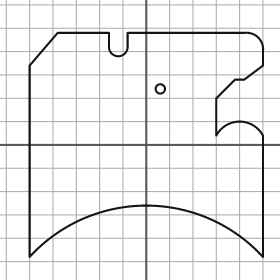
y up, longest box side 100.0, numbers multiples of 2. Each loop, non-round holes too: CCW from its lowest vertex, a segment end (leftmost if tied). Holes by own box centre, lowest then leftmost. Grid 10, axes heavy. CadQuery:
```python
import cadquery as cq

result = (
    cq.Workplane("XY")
    .moveTo(-50.0, -48.0)
    .threePointArc((0.0, -26.0), (50.0, -48.0))
    .lineTo(50.0, 4.0)
    .threePointArc((40.0, 10.0), (30.0, 4.0))
    .lineTo(30.0, 20.0)
    .lineTo(38.0, 28.0)
    .lineTo(42.0, 28.0)
    .lineTo(50.0, 34.0)
    .lineTo(50.0, 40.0)
    .threePointArc((48.0, 46.0), (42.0, 48.0))
    .lineTo(-8.0, 48.0)
    .lineTo(-8.0, 42.0)
    .threePointArc((-12.0, 38.0), (-16.0, 42.0))
    .lineTo(-16.0, 48.0)
    .lineTo(-38.0, 48.0)
    .lineTo(-50.0, 34.0)
    .close()
    .moveTo(6.0, 24.0)
    .circle(2.0)
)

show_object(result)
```